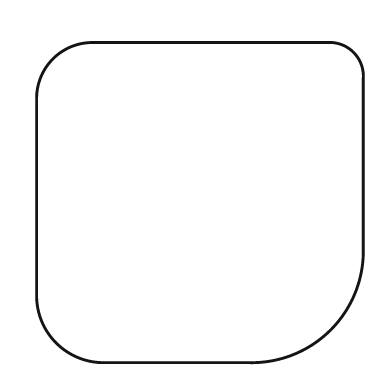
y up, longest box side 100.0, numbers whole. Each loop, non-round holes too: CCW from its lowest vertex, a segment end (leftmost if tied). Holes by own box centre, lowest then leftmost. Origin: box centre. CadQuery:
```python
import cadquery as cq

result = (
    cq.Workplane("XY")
    .moveTo(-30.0, -49.0)
    .lineTo(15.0, -49.0)
    .threePointArc((40.0, -39.0), (50.0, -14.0))
    .lineTo(50.0, 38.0)
    .threePointArc((47.0, 46.0), (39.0, 49.0))
    .lineTo(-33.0, 49.0)
    .threePointArc((-45.0, 44.0), (-50.0, 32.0))
    .lineTo(-50.0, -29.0)
    .threePointArc((-44.0, -43.0), (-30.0, -49.0))
    .close()
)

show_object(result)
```